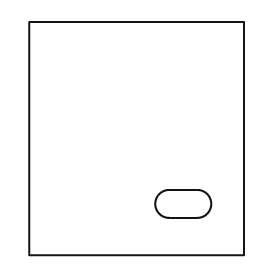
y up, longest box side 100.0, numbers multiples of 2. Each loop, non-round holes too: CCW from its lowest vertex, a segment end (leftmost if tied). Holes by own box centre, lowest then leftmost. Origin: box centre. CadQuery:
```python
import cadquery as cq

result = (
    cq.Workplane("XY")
    .moveTo(-46.0, -50.0)
    .lineTo(46.0, -50.0)
    .lineTo(46.0, 50.0)
    .lineTo(-46.0, 50.0)
    .close()
    .moveTo(14.0, -34.0)
    .lineTo(26.0, -34.0)
    .threePointArc((32.0, -28.0), (26.0, -22.0))
    .lineTo(14.0, -22.0)
    .threePointArc((8.0, -28.0), (14.0, -34.0))
    .close()
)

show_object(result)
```